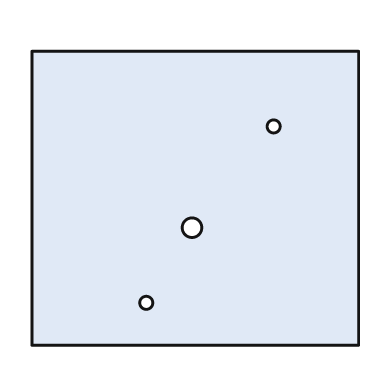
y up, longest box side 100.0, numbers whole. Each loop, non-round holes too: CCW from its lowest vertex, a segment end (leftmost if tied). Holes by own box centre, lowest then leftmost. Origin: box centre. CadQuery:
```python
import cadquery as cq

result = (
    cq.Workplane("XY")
    .moveTo(-50.0, -45.0)
    .lineTo(50.0, -45.0)
    .lineTo(50.0, 45.0)
    .lineTo(-50.0, 45.0)
    .close()
    .moveTo(-15.0, -32.0)
    .circle(2.0)
    .moveTo(-1.0, -9.0)
    .circle(3.0)
    .moveTo(24.0, 22.0)
    .circle(2.0)
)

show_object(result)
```